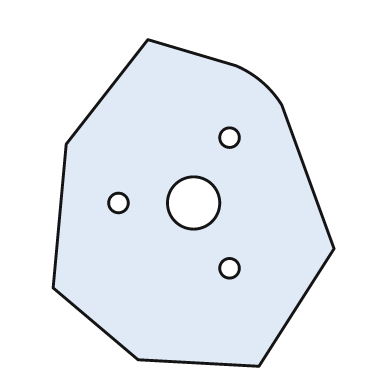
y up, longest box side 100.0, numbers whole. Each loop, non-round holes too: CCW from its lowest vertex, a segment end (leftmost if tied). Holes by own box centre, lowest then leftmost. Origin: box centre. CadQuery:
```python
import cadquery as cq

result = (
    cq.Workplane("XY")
    .moveTo(20.0, -50.0)
    .lineTo(43.0, -14.0)
    .lineTo(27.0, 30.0)
    .threePointArc((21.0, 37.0), (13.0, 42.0))
    .lineTo(-14.0, 50.0)
    .lineTo(-39.0, 18.0)
    .lineTo(-43.0, -26.0)
    .lineTo(-17.0, -48.0)
    .close()
    .moveTo(11.0, -20.0)
    .circle(3.0)
    .moveTo(-23.0, 0.0)
    .circle(3.0)
    .moveTo(0.0, 0.0)
    .circle(8.0)
    .moveTo(11.0, 20.0)
    .circle(3.0)
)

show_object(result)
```